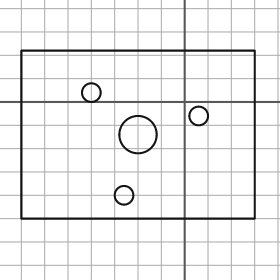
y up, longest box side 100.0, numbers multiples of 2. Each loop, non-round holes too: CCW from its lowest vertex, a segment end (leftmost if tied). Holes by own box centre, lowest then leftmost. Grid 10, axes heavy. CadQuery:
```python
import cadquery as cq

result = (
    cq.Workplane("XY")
    .moveTo(-70.0, -50.0)
    .lineTo(30.0, -50.0)
    .lineTo(30.0, 22.0)
    .lineTo(-70.0, 22.0)
    .close()
    .moveTo(-26.0, -40.0)
    .circle(4.0)
    .moveTo(-20.0, -14.0)
    .circle(8.0)
    .moveTo(6.0, -6.0)
    .circle(4.0)
    .moveTo(-40.0, 4.0)
    .circle(4.0)
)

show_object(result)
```